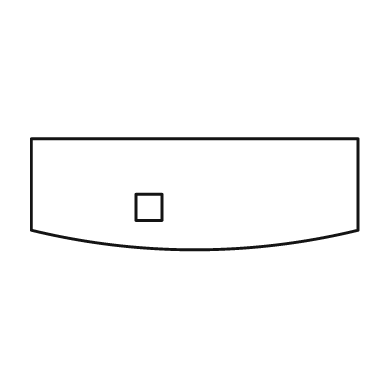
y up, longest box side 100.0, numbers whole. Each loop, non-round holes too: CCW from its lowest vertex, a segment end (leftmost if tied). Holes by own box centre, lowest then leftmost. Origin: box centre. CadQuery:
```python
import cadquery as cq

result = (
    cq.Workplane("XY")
    .moveTo(-50.0, -11.0)
    .threePointArc((0.0, -17.0), (50.0, -11.0))
    .lineTo(50.0, 17.0)
    .lineTo(-50.0, 17.0)
    .close()
    .moveTo(-18.0, -8.0)
    .lineTo(-10.0, -8.0)
    .lineTo(-10.0, 0.0)
    .lineTo(-18.0, 0.0)
    .close()
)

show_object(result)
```